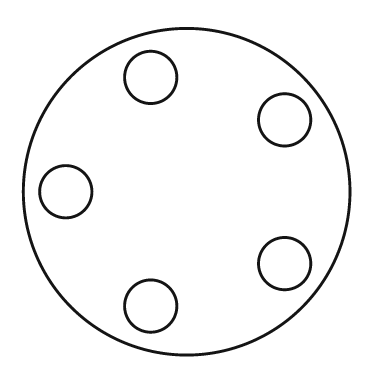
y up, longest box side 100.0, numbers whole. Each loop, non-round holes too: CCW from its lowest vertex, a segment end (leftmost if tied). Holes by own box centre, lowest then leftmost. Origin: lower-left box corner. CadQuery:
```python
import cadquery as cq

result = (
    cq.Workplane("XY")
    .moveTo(50.0, 50.0)
    .circle(50.0)
    .moveTo(39.0, 15.0)
    .circle(8.0)
    .moveTo(80.0, 28.0)
    .circle(8.0)
    .moveTo(13.0, 50.0)
    .circle(8.0)
    .moveTo(80.0, 72.0)
    .circle(8.0)
    .moveTo(39.0, 85.0)
    .circle(8.0)
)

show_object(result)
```